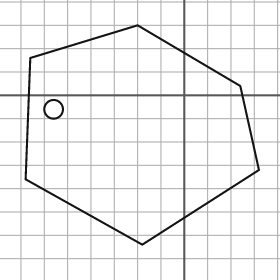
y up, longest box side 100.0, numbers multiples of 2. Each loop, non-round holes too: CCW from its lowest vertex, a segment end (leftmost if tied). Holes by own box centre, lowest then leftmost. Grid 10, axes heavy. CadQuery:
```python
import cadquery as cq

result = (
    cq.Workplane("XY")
    .moveTo(-18.0, -64.0)
    .lineTo(32.0, -32.0)
    .lineTo(24.0, 4.0)
    .lineTo(-20.0, 30.0)
    .lineTo(-66.0, 16.0)
    .lineTo(-68.0, -36.0)
    .close()
    .moveTo(-56.0, -6.0)
    .circle(4.0)
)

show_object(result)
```